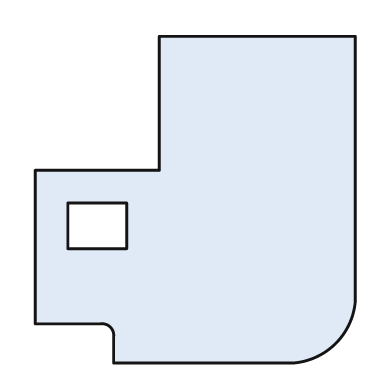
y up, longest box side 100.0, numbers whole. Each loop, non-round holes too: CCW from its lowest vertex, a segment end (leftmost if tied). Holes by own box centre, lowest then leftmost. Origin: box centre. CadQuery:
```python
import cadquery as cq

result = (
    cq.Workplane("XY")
    .moveTo(-25.0, -50.0)
    .lineTo(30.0, -50.0)
    .threePointArc((43.0, -44.0), (49.0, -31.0))
    .lineTo(49.0, 50.0)
    .lineTo(-11.0, 50.0)
    .lineTo(-11.0, 9.0)
    .lineTo(-49.0, 9.0)
    .lineTo(-49.0, -38.0)
    .lineTo(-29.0, -38.0)
    .threePointArc((-26.0, -39.0), (-25.0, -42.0))
    .close()
    .moveTo(-39.0, -15.0)
    .lineTo(-21.0, -15.0)
    .lineTo(-21.0, -1.0)
    .lineTo(-39.0, -1.0)
    .close()
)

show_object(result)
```